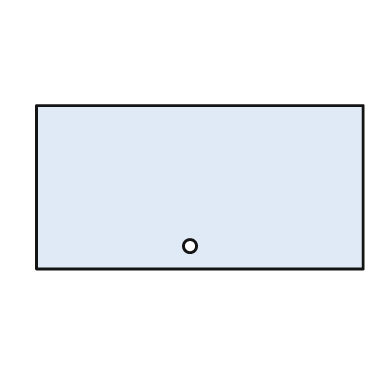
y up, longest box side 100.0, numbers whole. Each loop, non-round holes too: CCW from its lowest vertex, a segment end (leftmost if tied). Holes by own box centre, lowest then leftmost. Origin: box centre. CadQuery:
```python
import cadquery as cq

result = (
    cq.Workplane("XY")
    .moveTo(-50.0, -25.0)
    .lineTo(50.0, -25.0)
    .lineTo(50.0, 25.0)
    .lineTo(-50.0, 25.0)
    .close()
    .moveTo(-3.0, -18.0)
    .circle(2.0)
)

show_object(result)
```